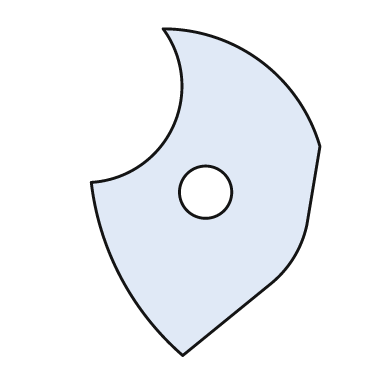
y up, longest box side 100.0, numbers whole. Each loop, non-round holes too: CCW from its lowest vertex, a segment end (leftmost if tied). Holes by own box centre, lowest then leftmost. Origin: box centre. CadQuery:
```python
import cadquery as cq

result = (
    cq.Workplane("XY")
    .moveTo(-7.0, -50.0)
    .lineTo(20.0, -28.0)
    .threePointArc((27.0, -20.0), (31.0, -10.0))
    .lineTo(35.0, 14.0)
    .threePointArc((17.0, 40.0), (-13.0, 50.0))
    .threePointArc((-10.0, 20.0), (-35.0, 3.0))
    .threePointArc((-26.0, -26.0), (-7.0, -50.0))
    .close()
    .moveTo(0.0, 0.0)
    .circle(8.0)
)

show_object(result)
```